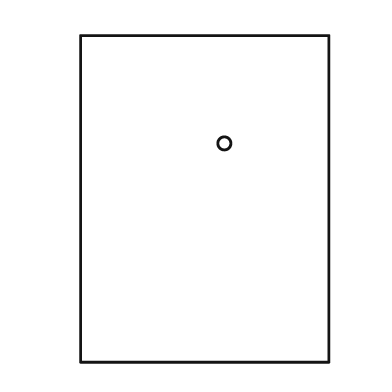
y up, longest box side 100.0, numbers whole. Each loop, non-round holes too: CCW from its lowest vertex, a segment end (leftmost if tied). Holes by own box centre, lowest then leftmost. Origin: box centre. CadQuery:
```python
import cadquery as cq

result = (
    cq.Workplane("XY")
    .moveTo(-38.0, -50.0)
    .lineTo(38.0, -50.0)
    .lineTo(38.0, 50.0)
    .lineTo(-38.0, 50.0)
    .close()
    .moveTo(6.0, 17.0)
    .circle(2.0)
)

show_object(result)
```